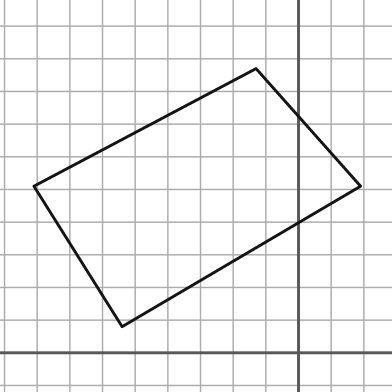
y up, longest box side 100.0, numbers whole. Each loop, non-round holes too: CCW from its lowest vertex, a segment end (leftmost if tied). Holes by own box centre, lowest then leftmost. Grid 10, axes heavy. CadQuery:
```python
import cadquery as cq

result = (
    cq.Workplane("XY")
    .moveTo(-54.0, 8.0)
    .lineTo(19.0, 51.0)
    .lineTo(-13.0, 87.0)
    .lineTo(-81.0, 51.0)
    .close()
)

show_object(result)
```